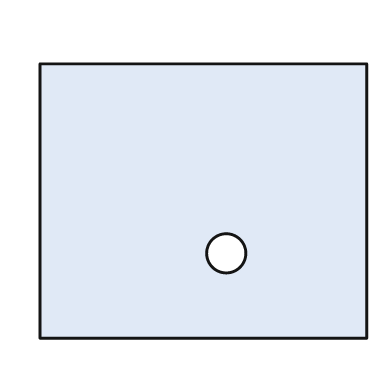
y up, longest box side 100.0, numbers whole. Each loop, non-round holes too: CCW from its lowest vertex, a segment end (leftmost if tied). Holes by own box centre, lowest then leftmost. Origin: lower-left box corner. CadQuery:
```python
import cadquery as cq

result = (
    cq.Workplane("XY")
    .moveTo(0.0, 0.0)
    .lineTo(100.0, 0.0)
    .lineTo(100.0, 84.0)
    .lineTo(0.0, 84.0)
    .close()
    .moveTo(57.0, 26.0)
    .circle(6.0)
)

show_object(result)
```